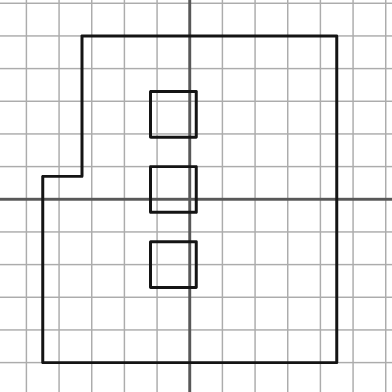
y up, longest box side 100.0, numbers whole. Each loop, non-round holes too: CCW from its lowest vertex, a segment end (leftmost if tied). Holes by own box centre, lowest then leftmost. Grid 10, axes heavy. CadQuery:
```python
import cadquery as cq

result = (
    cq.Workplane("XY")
    .moveTo(-45.0, -50.0)
    .lineTo(45.0, -50.0)
    .lineTo(45.0, 50.0)
    .lineTo(-33.0, 50.0)
    .lineTo(-33.0, 7.0)
    .lineTo(-45.0, 7.0)
    .close()
    .moveTo(-12.0, -27.0)
    .lineTo(2.0, -27.0)
    .lineTo(2.0, -13.0)
    .lineTo(-12.0, -13.0)
    .close()
    .moveTo(-12.0, -4.0)
    .lineTo(2.0, -4.0)
    .lineTo(2.0, 10.0)
    .lineTo(-12.0, 10.0)
    .close()
    .moveTo(-12.0, 19.0)
    .lineTo(2.0, 19.0)
    .lineTo(2.0, 33.0)
    .lineTo(-12.0, 33.0)
    .close()
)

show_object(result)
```